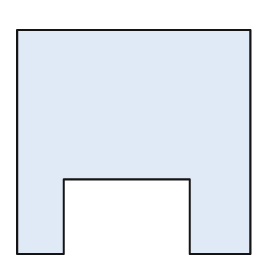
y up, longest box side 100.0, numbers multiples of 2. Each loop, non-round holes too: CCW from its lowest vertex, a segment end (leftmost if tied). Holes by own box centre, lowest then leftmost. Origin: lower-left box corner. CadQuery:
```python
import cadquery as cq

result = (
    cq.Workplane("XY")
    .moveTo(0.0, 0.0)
    .lineTo(20.0, 0.0)
    .lineTo(20.0, 32.0)
    .lineTo(74.0, 32.0)
    .lineTo(74.0, 0.0)
    .lineTo(100.0, 0.0)
    .lineTo(100.0, 96.0)
    .lineTo(0.0, 96.0)
    .close()
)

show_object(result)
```